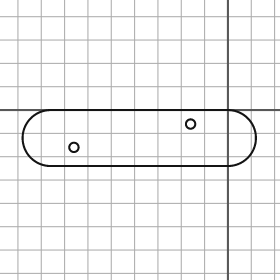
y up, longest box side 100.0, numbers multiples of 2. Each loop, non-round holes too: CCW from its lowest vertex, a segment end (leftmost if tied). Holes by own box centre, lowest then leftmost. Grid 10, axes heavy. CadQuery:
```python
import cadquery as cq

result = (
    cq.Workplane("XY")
    .moveTo(-76.0, -24.0)
    .lineTo(0.0, -24.0)
    .threePointArc((12.0, -12.0), (0.0, 0.0))
    .lineTo(-76.0, 0.0)
    .threePointArc((-88.0, -12.0), (-76.0, -24.0))
    .close()
    .moveTo(-66.0, -16.0)
    .circle(2.0)
    .moveTo(-16.0, -6.0)
    .circle(2.0)
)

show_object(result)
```